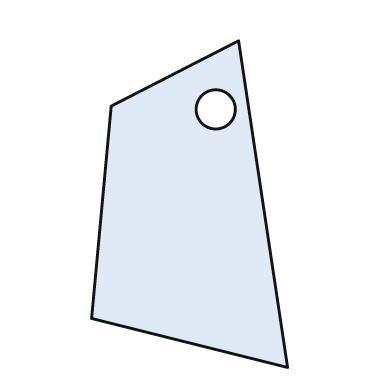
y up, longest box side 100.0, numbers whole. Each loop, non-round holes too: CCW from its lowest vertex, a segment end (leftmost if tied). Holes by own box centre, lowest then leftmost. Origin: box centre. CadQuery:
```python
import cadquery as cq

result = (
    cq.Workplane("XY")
    .moveTo(30.0, -50.0)
    .lineTo(15.0, 50.0)
    .lineTo(-24.0, 30.0)
    .lineTo(-30.0, -35.0)
    .close()
    .moveTo(8.0, 29.0)
    .circle(6.0)
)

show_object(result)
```